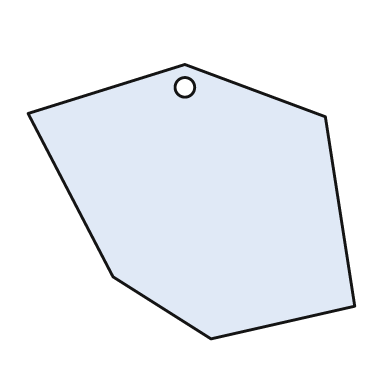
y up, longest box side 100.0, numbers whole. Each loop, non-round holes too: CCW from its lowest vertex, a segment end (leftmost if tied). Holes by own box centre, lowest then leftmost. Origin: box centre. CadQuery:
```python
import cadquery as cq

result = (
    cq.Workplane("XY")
    .moveTo(6.0, -42.0)
    .lineTo(50.0, -32.0)
    .lineTo(41.0, 26.0)
    .lineTo(-2.0, 42.0)
    .lineTo(-50.0, 27.0)
    .lineTo(-24.0, -23.0)
    .close()
    .moveTo(-2.0, 35.0)
    .circle(3.0)
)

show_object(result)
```